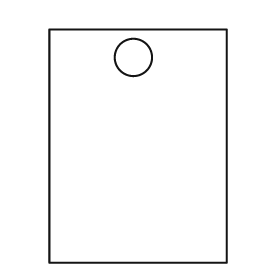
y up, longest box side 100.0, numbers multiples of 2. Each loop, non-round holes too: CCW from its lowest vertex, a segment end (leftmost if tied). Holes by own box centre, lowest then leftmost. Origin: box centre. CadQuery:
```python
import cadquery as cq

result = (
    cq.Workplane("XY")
    .moveTo(-38.0, -50.0)
    .lineTo(38.0, -50.0)
    .lineTo(38.0, 50.0)
    .lineTo(-38.0, 50.0)
    .close()
    .moveTo(-2.0, 38.0)
    .circle(8.0)
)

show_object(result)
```